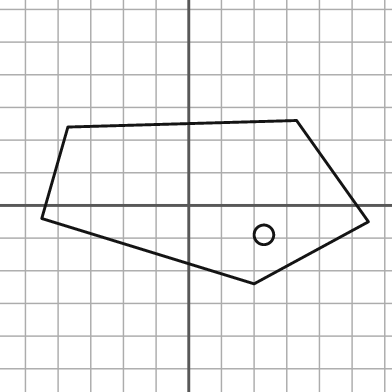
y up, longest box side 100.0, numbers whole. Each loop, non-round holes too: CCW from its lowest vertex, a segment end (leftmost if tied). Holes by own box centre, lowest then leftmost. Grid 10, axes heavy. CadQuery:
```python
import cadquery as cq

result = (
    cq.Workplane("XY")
    .moveTo(20.0, -24.0)
    .lineTo(55.0, -5.0)
    .lineTo(33.0, 26.0)
    .lineTo(-37.0, 24.0)
    .lineTo(-45.0, -4.0)
    .close()
    .moveTo(23.0, -9.0)
    .circle(3.0)
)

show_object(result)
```